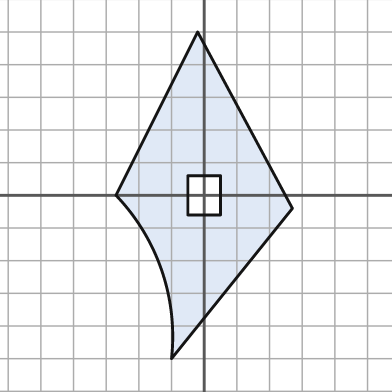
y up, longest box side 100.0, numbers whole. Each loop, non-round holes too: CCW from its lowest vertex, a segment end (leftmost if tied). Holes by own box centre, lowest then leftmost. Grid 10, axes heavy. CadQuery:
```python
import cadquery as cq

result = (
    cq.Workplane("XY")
    .moveTo(-10.0, -50.0)
    .lineTo(27.0, -4.0)
    .lineTo(-2.0, 50.0)
    .lineTo(-27.0, 0.0)
    .threePointArc((-13.0, -23.0), (-10.0, -50.0))
    .close()
    .moveTo(-5.0, -6.0)
    .lineTo(5.0, -6.0)
    .lineTo(5.0, 6.0)
    .lineTo(-5.0, 6.0)
    .close()
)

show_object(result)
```